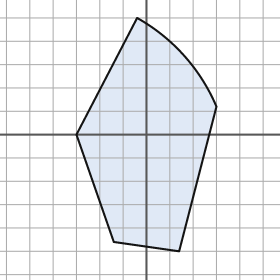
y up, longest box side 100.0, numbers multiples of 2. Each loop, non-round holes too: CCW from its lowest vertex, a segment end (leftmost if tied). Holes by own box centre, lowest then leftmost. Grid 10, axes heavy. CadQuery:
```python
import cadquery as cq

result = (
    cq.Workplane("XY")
    .moveTo(14.0, -50.0)
    .lineTo(30.0, 12.0)
    .threePointArc((16.0, 34.0), (-4.0, 50.0))
    .lineTo(-30.0, 0.0)
    .lineTo(-14.0, -46.0)
    .close()
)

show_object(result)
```